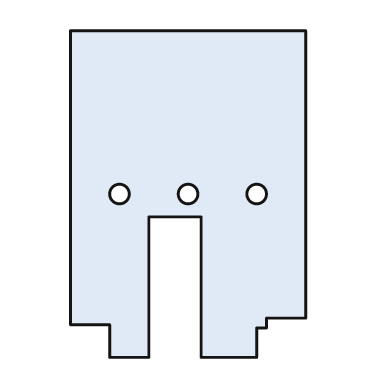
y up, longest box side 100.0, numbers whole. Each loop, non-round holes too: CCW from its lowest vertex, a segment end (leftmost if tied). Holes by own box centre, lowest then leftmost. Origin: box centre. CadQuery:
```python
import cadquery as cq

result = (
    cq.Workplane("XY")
    .moveTo(-24.0, -50.0)
    .lineTo(-12.0, -50.0)
    .lineTo(-12.0, -7.0)
    .lineTo(4.0, -7.0)
    .lineTo(4.0, -50.0)
    .lineTo(21.0, -50.0)
    .lineTo(21.0, -41.0)
    .lineTo(24.0, -41.0)
    .lineTo(24.0, -38.0)
    .lineTo(36.0, -38.0)
    .lineTo(36.0, 50.0)
    .lineTo(-36.0, 50.0)
    .lineTo(-36.0, -40.0)
    .lineTo(-24.0, -40.0)
    .close()
    .moveTo(-21.0, 0.0)
    .circle(3.0)
    .moveTo(0.0, 0.0)
    .circle(3.0)
    .moveTo(21.0, 0.0)
    .circle(3.0)
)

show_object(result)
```